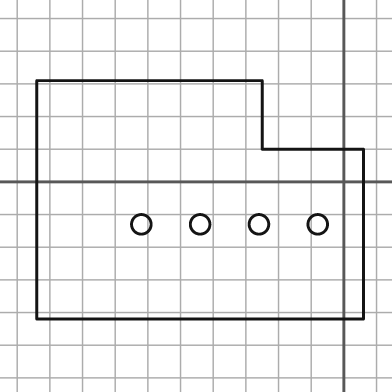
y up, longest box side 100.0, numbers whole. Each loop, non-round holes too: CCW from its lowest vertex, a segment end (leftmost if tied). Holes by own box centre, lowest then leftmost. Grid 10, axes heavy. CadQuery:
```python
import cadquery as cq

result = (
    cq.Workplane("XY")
    .moveTo(-94.0, -42.0)
    .lineTo(6.0, -42.0)
    .lineTo(6.0, 10.0)
    .lineTo(-25.0, 10.0)
    .lineTo(-25.0, 31.0)
    .lineTo(-94.0, 31.0)
    .close()
    .moveTo(-62.0, -13.0)
    .circle(3.0)
    .moveTo(-44.0, -13.0)
    .circle(3.0)
    .moveTo(-26.0, -13.0)
    .circle(3.0)
    .moveTo(-8.0, -13.0)
    .circle(3.0)
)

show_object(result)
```